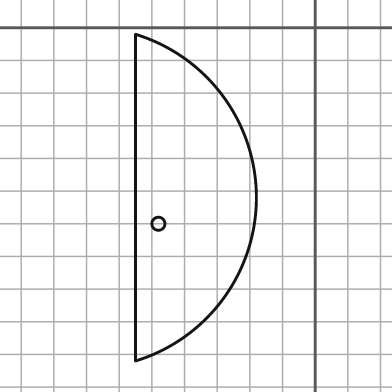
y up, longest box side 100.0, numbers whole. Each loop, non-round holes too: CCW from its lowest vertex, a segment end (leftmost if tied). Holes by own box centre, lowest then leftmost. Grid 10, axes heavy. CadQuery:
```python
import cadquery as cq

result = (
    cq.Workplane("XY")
    .moveTo(-55.0, -102.0)
    .threePointArc((-18.0, -52.0), (-55.0, -2.0))
    .close()
    .moveTo(-48.0, -60.0)
    .circle(2.0)
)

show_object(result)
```